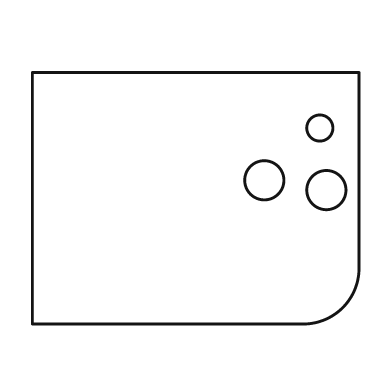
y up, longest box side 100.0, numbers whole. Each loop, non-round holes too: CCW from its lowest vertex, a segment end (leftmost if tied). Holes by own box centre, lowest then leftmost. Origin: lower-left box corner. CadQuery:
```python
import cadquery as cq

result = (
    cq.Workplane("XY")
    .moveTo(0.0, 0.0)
    .lineTo(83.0, 0.0)
    .threePointArc((95.0, 5.0), (100.0, 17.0))
    .lineTo(100.0, 77.0)
    .lineTo(0.0, 77.0)
    .close()
    .moveTo(90.0, 41.0)
    .circle(6.0)
    .moveTo(71.0, 44.0)
    .circle(6.0)
    .moveTo(88.0, 60.0)
    .circle(4.0)
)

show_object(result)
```